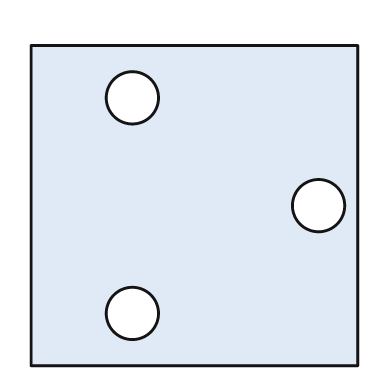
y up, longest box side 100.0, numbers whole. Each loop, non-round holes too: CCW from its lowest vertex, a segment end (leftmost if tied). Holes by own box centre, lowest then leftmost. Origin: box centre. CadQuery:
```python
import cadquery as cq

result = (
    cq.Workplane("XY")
    .moveTo(-50.0, -49.0)
    .lineTo(50.0, -49.0)
    .lineTo(50.0, 49.0)
    .lineTo(-50.0, 49.0)
    .close()
    .moveTo(-19.0, -33.0)
    .circle(8.0)
    .moveTo(38.0, 0.0)
    .circle(8.0)
    .moveTo(-19.0, 33.0)
    .circle(8.0)
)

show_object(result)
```